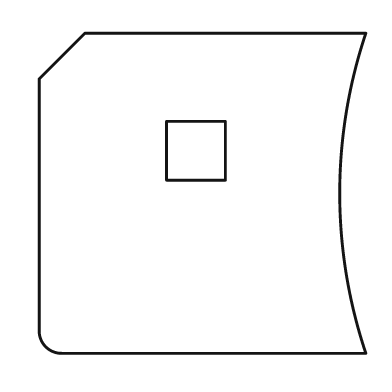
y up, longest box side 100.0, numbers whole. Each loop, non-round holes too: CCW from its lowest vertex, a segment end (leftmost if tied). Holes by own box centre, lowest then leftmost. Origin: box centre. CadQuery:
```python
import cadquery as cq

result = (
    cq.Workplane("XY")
    .moveTo(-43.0, -49.0)
    .lineTo(50.0, -49.0)
    .threePointArc((42.0, 0.0), (50.0, 49.0))
    .lineTo(-36.0, 49.0)
    .lineTo(-50.0, 35.0)
    .lineTo(-50.0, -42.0)
    .threePointArc((-48.0, -47.0), (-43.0, -49.0))
    .close()
    .moveTo(-11.0, 4.0)
    .lineTo(7.0, 4.0)
    .lineTo(7.0, 22.0)
    .lineTo(-11.0, 22.0)
    .close()
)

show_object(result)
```